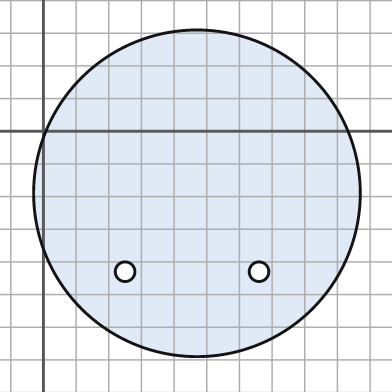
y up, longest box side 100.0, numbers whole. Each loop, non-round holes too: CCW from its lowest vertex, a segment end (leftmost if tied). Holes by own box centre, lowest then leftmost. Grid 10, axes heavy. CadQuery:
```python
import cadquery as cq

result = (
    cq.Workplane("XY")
    .moveTo(47.0, -19.0)
    .circle(50.0)
    .moveTo(25.0, -43.0)
    .circle(3.0)
    .moveTo(66.0, -43.0)
    .circle(3.0)
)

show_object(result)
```